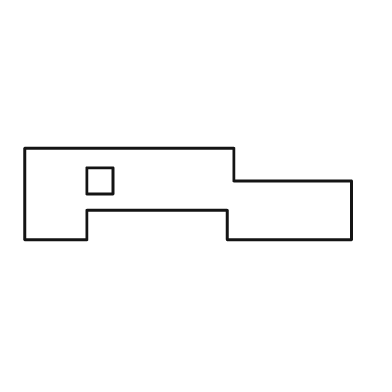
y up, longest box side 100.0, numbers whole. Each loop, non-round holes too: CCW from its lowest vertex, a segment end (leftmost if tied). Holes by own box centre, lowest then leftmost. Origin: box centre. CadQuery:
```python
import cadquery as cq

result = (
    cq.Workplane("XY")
    .moveTo(-50.0, -14.0)
    .lineTo(-31.0, -14.0)
    .lineTo(-31.0, -5.0)
    .lineTo(12.0, -5.0)
    .lineTo(12.0, -14.0)
    .lineTo(50.0, -14.0)
    .lineTo(50.0, 4.0)
    .lineTo(14.0, 4.0)
    .lineTo(14.0, 14.0)
    .lineTo(-50.0, 14.0)
    .close()
    .moveTo(-31.0, 0.0)
    .lineTo(-23.0, 0.0)
    .lineTo(-23.0, 8.0)
    .lineTo(-31.0, 8.0)
    .close()
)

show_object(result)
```